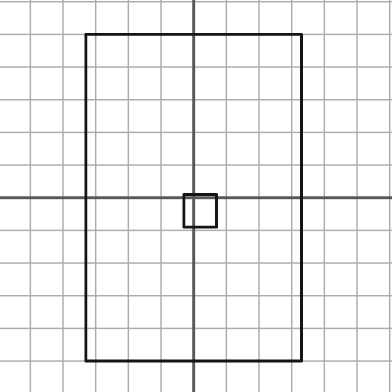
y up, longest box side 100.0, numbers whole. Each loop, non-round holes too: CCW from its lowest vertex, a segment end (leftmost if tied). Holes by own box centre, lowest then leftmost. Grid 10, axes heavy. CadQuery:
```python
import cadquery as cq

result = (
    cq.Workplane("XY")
    .moveTo(-33.0, -50.0)
    .lineTo(33.0, -50.0)
    .lineTo(33.0, 50.0)
    .lineTo(-33.0, 50.0)
    .close()
    .moveTo(-3.0, -9.0)
    .lineTo(7.0, -9.0)
    .lineTo(7.0, 1.0)
    .lineTo(-3.0, 1.0)
    .close()
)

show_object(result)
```